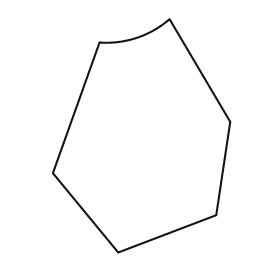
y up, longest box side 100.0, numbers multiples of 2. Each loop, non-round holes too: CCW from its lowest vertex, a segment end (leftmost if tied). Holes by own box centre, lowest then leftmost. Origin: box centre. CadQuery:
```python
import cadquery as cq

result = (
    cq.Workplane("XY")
    .moveTo(-10.0, -50.0)
    .lineTo(32.0, -34.0)
    .lineTo(38.0, 6.0)
    .lineTo(12.0, 50.0)
    .threePointArc((-2.0, 42.0), (-18.0, 40.0))
    .lineTo(-38.0, -16.0)
    .close()
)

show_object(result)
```